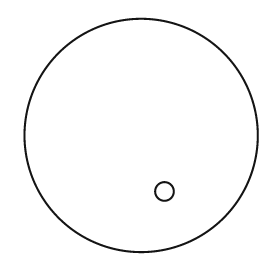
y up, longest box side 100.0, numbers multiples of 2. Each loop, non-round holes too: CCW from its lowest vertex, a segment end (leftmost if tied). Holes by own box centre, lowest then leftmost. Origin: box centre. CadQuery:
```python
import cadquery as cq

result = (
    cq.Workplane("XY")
    .moveTo(0.0, 0.0)
    .circle(50.0)
    .moveTo(10.0, -24.0)
    .circle(4.0)
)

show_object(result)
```